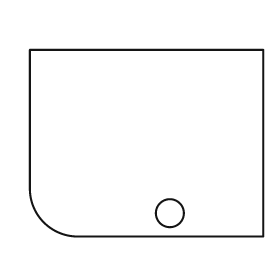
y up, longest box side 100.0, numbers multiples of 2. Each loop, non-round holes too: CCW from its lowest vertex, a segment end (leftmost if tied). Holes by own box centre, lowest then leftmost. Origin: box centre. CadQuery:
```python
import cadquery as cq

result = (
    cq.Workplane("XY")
    .moveTo(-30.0, -40.0)
    .lineTo(50.0, -40.0)
    .lineTo(50.0, 40.0)
    .lineTo(-50.0, 40.0)
    .lineTo(-50.0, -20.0)
    .threePointArc((-44.0, -34.0), (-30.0, -40.0))
    .close()
    .moveTo(10.0, -30.0)
    .circle(6.0)
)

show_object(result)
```